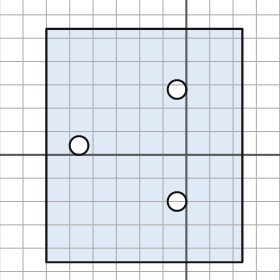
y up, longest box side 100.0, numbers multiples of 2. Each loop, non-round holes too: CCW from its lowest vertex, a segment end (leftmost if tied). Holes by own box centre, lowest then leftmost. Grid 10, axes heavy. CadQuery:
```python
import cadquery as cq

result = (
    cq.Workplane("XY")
    .moveTo(-60.0, -46.0)
    .lineTo(24.0, -46.0)
    .lineTo(24.0, 54.0)
    .lineTo(-60.0, 54.0)
    .close()
    .moveTo(-4.0, -20.0)
    .circle(4.0)
    .moveTo(-46.0, 4.0)
    .circle(4.0)
    .moveTo(-4.0, 28.0)
    .circle(4.0)
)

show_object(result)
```